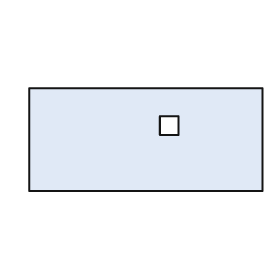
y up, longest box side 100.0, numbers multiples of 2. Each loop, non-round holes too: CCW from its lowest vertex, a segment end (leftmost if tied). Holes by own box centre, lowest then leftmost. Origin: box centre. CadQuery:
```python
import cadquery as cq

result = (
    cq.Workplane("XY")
    .moveTo(-50.0, -22.0)
    .lineTo(50.0, -22.0)
    .lineTo(50.0, 22.0)
    .lineTo(-50.0, 22.0)
    .close()
    .moveTo(6.0, 2.0)
    .lineTo(14.0, 2.0)
    .lineTo(14.0, 10.0)
    .lineTo(6.0, 10.0)
    .close()
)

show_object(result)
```